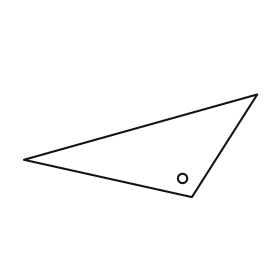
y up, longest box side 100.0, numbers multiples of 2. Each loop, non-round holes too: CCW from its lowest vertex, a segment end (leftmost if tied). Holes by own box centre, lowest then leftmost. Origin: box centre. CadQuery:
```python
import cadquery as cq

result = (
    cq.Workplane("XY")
    .moveTo(22.0, -22.0)
    .lineTo(50.0, 22.0)
    .lineTo(-50.0, -6.0)
    .close()
    .moveTo(18.0, -14.0)
    .circle(2.0)
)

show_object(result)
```